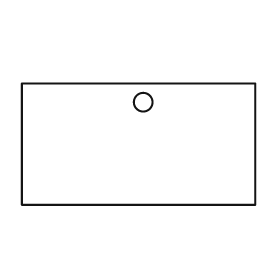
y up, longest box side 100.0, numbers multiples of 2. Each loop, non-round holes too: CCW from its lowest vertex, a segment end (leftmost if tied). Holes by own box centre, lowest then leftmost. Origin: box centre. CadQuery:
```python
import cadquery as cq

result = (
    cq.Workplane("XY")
    .moveTo(-50.0, -26.0)
    .lineTo(50.0, -26.0)
    .lineTo(50.0, 26.0)
    .lineTo(-50.0, 26.0)
    .close()
    .moveTo(2.0, 18.0)
    .circle(4.0)
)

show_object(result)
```